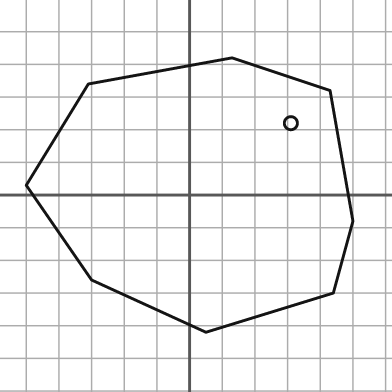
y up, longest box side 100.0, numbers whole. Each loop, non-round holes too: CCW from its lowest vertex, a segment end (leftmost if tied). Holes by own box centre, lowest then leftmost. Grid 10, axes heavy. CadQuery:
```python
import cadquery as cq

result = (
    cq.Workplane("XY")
    .moveTo(5.0, -42.0)
    .lineTo(44.0, -30.0)
    .lineTo(50.0, -8.0)
    .lineTo(43.0, 32.0)
    .lineTo(13.0, 42.0)
    .lineTo(-31.0, 34.0)
    .lineTo(-50.0, 3.0)
    .lineTo(-30.0, -26.0)
    .close()
    .moveTo(31.0, 22.0)
    .circle(2.0)
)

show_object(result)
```